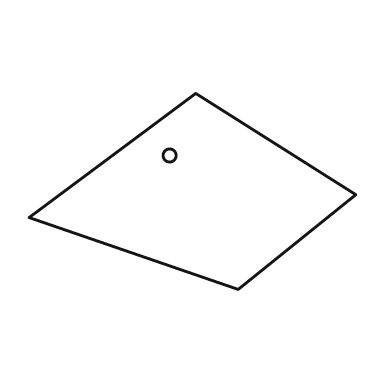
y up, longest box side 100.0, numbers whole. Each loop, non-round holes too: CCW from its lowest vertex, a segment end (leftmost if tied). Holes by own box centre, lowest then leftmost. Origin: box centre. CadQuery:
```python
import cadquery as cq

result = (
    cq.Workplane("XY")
    .moveTo(14.0, -30.0)
    .lineTo(50.0, -1.0)
    .lineTo(1.0, 30.0)
    .lineTo(-50.0, -8.0)
    .close()
    .moveTo(-7.0, 11.0)
    .circle(2.0)
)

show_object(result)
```